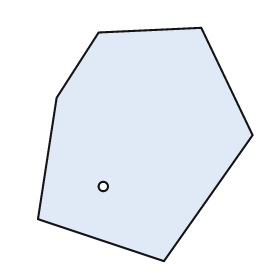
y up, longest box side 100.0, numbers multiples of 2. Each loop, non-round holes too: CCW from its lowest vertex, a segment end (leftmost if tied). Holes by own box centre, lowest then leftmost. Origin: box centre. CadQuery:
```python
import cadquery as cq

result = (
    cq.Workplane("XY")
    .moveTo(8.0, -50.0)
    .lineTo(46.0, 4.0)
    .lineTo(24.0, 50.0)
    .lineTo(-20.0, 48.0)
    .lineTo(-38.0, 20.0)
    .lineTo(-46.0, -32.0)
    .close()
    .moveTo(-18.0, -18.0)
    .circle(2.0)
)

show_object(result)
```